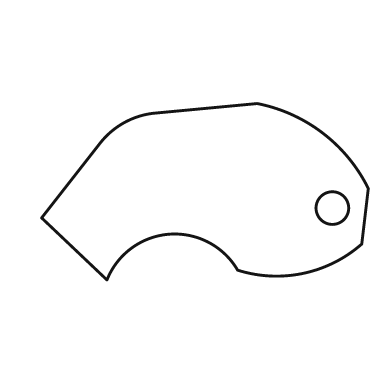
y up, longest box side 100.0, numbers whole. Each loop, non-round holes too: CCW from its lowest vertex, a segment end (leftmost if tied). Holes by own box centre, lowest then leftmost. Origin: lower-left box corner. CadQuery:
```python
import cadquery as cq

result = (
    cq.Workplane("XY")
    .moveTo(20.0, 0.0)
    .threePointArc((39.0, 14.0), (60.0, 3.0))
    .threePointArc((80.0, 2.0), (98.0, 11.0))
    .lineTo(100.0, 28.0)
    .threePointArc((86.0, 45.0), (66.0, 54.0))
    .lineTo(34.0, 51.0)
    .threePointArc((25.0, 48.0), (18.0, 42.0))
    .lineTo(0.0, 19.0)
    .close()
    .moveTo(89.0, 22.0)
    .circle(5.0)
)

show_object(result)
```